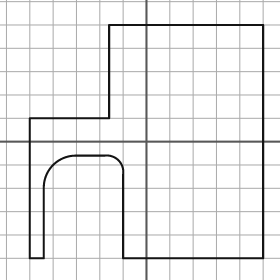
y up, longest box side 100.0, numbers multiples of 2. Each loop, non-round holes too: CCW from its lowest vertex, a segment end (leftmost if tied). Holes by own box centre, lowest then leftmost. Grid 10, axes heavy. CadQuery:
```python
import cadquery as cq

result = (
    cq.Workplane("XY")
    .moveTo(-50.0, -50.0)
    .lineTo(-44.0, -50.0)
    .lineTo(-44.0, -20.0)
    .threePointArc((-40.0, -10.0), (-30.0, -6.0))
    .lineTo(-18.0, -6.0)
    .threePointArc((-12.0, -8.0), (-10.0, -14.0))
    .lineTo(-10.0, -50.0)
    .lineTo(50.0, -50.0)
    .lineTo(50.0, 50.0)
    .lineTo(-16.0, 50.0)
    .lineTo(-16.0, 10.0)
    .lineTo(-50.0, 10.0)
    .close()
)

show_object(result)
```